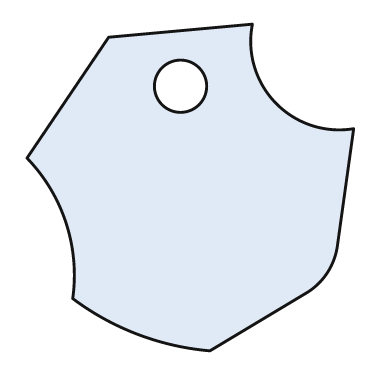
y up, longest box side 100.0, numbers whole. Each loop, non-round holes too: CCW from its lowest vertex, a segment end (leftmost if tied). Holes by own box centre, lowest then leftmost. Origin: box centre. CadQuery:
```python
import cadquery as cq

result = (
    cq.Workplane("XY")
    .moveTo(6.0, -50.0)
    .lineTo(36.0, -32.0)
    .threePointArc((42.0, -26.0), (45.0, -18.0))
    .lineTo(50.0, 18.0)
    .threePointArc((26.0, 26.0), (19.0, 50.0))
    .lineTo(-25.0, 46.0)
    .lineTo(-50.0, 9.0)
    .threePointArc((-38.0, -11.0), (-36.0, -34.0))
    .threePointArc((-16.0, -45.0), (6.0, -50.0))
    .close()
    .moveTo(-3.0, 31.0)
    .circle(8.0)
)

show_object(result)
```